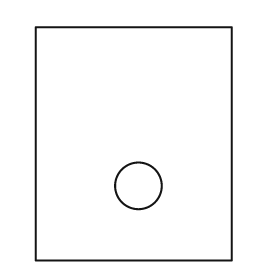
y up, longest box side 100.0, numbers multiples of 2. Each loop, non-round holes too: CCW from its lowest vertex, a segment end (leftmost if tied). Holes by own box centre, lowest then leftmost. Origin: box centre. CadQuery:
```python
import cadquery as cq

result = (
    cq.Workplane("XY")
    .moveTo(-42.0, -50.0)
    .lineTo(42.0, -50.0)
    .lineTo(42.0, 50.0)
    .lineTo(-42.0, 50.0)
    .close()
    .moveTo(2.0, -18.0)
    .circle(10.0)
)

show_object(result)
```